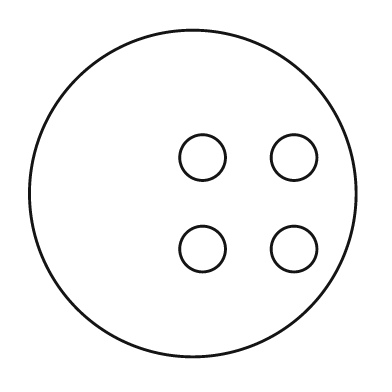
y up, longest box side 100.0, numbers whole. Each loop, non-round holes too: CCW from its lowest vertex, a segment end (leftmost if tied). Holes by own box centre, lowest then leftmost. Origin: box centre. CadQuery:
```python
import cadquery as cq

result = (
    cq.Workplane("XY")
    .moveTo(0.0, 0.0)
    .circle(50.0)
    .moveTo(3.0, -17.0)
    .circle(7.0)
    .moveTo(31.0, -17.0)
    .circle(7.0)
    .moveTo(3.0, 11.0)
    .circle(7.0)
    .moveTo(31.0, 11.0)
    .circle(7.0)
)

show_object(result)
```